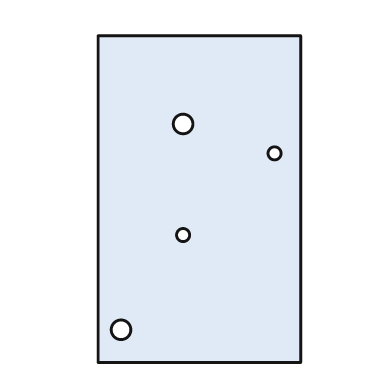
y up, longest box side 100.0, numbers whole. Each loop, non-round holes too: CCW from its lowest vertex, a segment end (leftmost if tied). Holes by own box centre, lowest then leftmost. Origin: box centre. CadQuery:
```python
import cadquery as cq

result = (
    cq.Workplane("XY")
    .moveTo(-31.0, -50.0)
    .lineTo(31.0, -50.0)
    .lineTo(31.0, 50.0)
    .lineTo(-31.0, 50.0)
    .close()
    .moveTo(-24.0, -40.0)
    .circle(3.0)
    .moveTo(-5.0, -11.0)
    .circle(2.0)
    .moveTo(23.0, 14.0)
    .circle(2.0)
    .moveTo(-5.0, 23.0)
    .circle(3.0)
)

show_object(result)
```